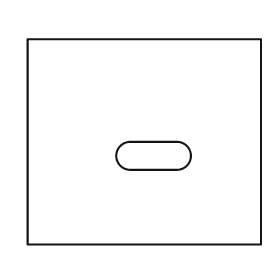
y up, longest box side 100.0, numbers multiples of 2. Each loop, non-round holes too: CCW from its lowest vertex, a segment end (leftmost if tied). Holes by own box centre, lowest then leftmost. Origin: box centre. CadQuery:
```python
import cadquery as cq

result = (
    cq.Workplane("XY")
    .moveTo(-50.0, -44.0)
    .lineTo(50.0, -44.0)
    .lineTo(50.0, 44.0)
    .lineTo(-50.0, 44.0)
    .close()
    .moveTo(-6.0, -12.0)
    .lineTo(14.0, -12.0)
    .threePointArc((20.0, -6.0), (14.0, 0.0))
    .lineTo(-6.0, 0.0)
    .threePointArc((-12.0, -6.0), (-6.0, -12.0))
    .close()
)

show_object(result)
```